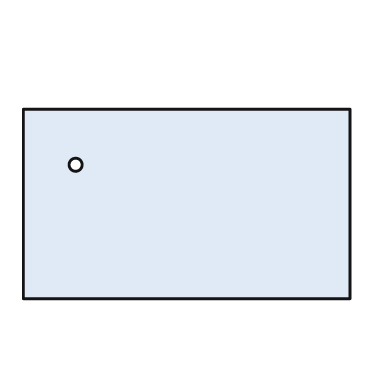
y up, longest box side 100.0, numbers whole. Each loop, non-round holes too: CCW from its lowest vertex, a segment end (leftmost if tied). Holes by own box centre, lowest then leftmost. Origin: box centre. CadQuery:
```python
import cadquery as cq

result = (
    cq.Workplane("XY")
    .moveTo(-50.0, -29.0)
    .lineTo(50.0, -29.0)
    .lineTo(50.0, 29.0)
    .lineTo(-50.0, 29.0)
    .close()
    .moveTo(-34.0, 12.0)
    .circle(2.0)
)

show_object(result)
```